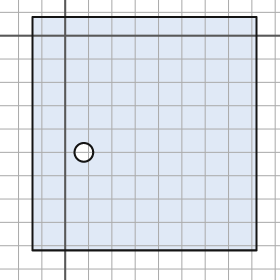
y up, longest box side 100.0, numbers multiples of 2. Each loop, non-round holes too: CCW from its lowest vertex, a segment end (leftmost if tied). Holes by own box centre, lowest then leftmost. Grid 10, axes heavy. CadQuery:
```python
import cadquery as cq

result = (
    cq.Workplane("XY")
    .moveTo(-14.0, -92.0)
    .lineTo(82.0, -92.0)
    .lineTo(82.0, 8.0)
    .lineTo(-14.0, 8.0)
    .close()
    .moveTo(8.0, -50.0)
    .circle(4.0)
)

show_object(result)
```